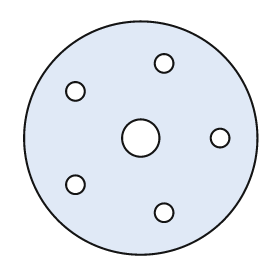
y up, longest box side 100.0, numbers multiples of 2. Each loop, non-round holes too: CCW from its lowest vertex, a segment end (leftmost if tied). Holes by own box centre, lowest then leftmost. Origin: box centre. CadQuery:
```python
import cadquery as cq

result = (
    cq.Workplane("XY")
    .moveTo(0.0, 0.0)
    .circle(50.0)
    .moveTo(10.0, -32.0)
    .circle(4.0)
    .moveTo(-28.0, -20.0)
    .circle(4.0)
    .moveTo(0.0, 0.0)
    .circle(8.0)
    .moveTo(34.0, 0.0)
    .circle(4.0)
    .moveTo(-28.0, 20.0)
    .circle(4.0)
    .moveTo(10.0, 32.0)
    .circle(4.0)
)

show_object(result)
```